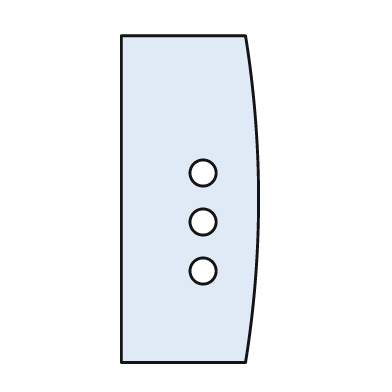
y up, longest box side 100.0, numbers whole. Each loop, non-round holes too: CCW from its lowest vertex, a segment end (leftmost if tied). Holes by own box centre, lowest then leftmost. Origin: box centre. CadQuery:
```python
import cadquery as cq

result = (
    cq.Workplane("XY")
    .moveTo(-21.0, -50.0)
    .lineTo(17.0, -50.0)
    .threePointArc((21.0, 0.0), (17.0, 50.0))
    .lineTo(-21.0, 50.0)
    .close()
    .moveTo(4.0, -22.0)
    .circle(4.0)
    .moveTo(4.0, -7.0)
    .circle(4.0)
    .moveTo(4.0, 8.0)
    .circle(4.0)
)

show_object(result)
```